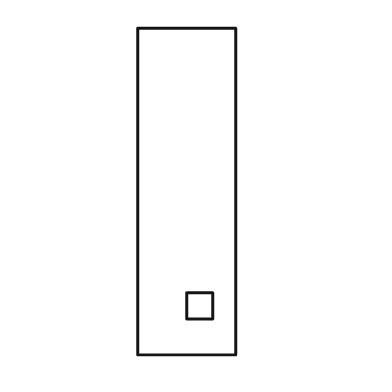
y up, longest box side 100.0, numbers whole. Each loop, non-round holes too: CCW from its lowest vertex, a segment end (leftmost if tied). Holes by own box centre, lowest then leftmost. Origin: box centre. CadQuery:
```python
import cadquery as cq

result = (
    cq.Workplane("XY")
    .moveTo(-15.0, -50.0)
    .lineTo(15.0, -50.0)
    .lineTo(15.0, 50.0)
    .lineTo(-15.0, 50.0)
    .close()
    .moveTo(0.0, -39.0)
    .lineTo(8.0, -39.0)
    .lineTo(8.0, -31.0)
    .lineTo(0.0, -31.0)
    .close()
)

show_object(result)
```